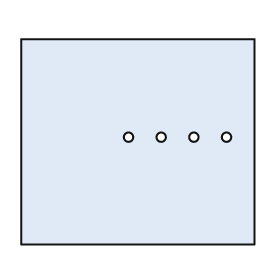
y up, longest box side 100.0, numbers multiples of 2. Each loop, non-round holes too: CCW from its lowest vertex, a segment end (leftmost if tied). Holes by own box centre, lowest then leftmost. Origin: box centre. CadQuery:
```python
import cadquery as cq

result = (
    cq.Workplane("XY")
    .moveTo(-50.0, -44.0)
    .lineTo(50.0, -44.0)
    .lineTo(50.0, 44.0)
    .lineTo(-50.0, 44.0)
    .close()
    .moveTo(-4.0, 2.0)
    .circle(2.0)
    .moveTo(10.0, 2.0)
    .circle(2.0)
    .moveTo(24.0, 2.0)
    .circle(2.0)
    .moveTo(38.0, 2.0)
    .circle(2.0)
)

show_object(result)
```